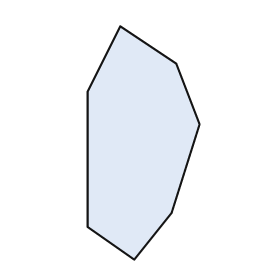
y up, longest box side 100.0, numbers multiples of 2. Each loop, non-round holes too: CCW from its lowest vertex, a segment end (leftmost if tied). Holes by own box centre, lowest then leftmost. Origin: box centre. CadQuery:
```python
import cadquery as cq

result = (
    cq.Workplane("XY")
    .moveTo(-4.0, -50.0)
    .lineTo(12.0, -30.0)
    .lineTo(24.0, 8.0)
    .lineTo(14.0, 34.0)
    .lineTo(-10.0, 50.0)
    .lineTo(-24.0, 22.0)
    .lineTo(-24.0, -36.0)
    .close()
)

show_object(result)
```